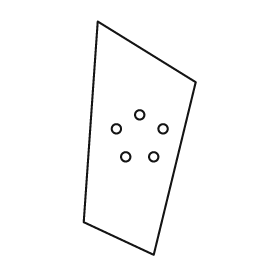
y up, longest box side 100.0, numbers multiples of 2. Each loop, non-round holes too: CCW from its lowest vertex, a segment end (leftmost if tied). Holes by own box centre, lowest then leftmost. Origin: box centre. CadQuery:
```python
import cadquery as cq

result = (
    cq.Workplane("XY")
    .moveTo(6.0, -50.0)
    .lineTo(24.0, 24.0)
    .lineTo(-18.0, 50.0)
    .lineTo(-24.0, -36.0)
    .close()
    .moveTo(-6.0, -8.0)
    .circle(2.0)
    .moveTo(6.0, -8.0)
    .circle(2.0)
    .moveTo(-10.0, 4.0)
    .circle(2.0)
    .moveTo(10.0, 4.0)
    .circle(2.0)
    .moveTo(0.0, 10.0)
    .circle(2.0)
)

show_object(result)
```